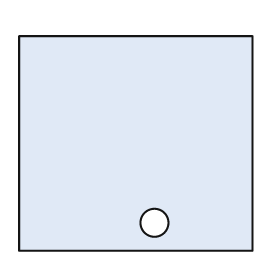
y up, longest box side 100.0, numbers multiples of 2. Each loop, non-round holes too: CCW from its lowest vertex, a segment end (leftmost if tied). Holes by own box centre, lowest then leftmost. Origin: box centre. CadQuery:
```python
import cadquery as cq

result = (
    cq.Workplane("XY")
    .moveTo(-50.0, -46.0)
    .lineTo(50.0, -46.0)
    .lineTo(50.0, 46.0)
    .lineTo(-50.0, 46.0)
    .close()
    .moveTo(8.0, -34.0)
    .circle(6.0)
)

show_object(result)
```